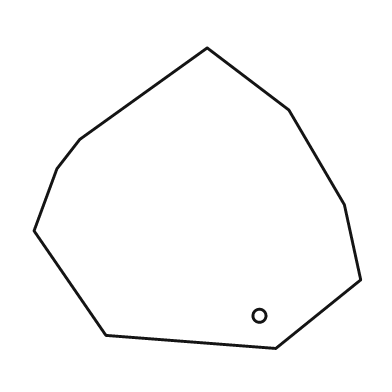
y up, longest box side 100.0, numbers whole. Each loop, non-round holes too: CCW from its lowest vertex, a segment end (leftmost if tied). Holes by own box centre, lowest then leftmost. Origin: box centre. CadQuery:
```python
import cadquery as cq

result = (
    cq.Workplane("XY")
    .moveTo(24.0, -46.0)
    .lineTo(50.0, -25.0)
    .lineTo(45.0, -2.0)
    .lineTo(28.0, 27.0)
    .lineTo(3.0, 46.0)
    .lineTo(-36.0, 18.0)
    .lineTo(-43.0, 9.0)
    .lineTo(-50.0, -10.0)
    .lineTo(-28.0, -42.0)
    .close()
    .moveTo(19.0, -36.0)
    .circle(2.0)
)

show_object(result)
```